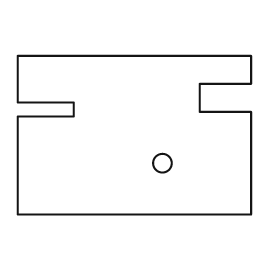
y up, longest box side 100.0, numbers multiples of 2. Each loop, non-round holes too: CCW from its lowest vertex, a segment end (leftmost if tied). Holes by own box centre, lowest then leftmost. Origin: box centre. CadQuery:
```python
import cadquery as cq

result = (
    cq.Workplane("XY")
    .moveTo(-50.0, -34.0)
    .lineTo(50.0, -34.0)
    .lineTo(50.0, 10.0)
    .lineTo(28.0, 10.0)
    .lineTo(28.0, 22.0)
    .lineTo(50.0, 22.0)
    .lineTo(50.0, 34.0)
    .lineTo(-50.0, 34.0)
    .lineTo(-50.0, 14.0)
    .lineTo(-26.0, 14.0)
    .lineTo(-26.0, 8.0)
    .lineTo(-50.0, 8.0)
    .close()
    .moveTo(12.0, -12.0)
    .circle(4.0)
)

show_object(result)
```